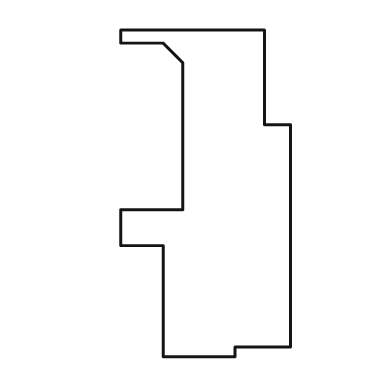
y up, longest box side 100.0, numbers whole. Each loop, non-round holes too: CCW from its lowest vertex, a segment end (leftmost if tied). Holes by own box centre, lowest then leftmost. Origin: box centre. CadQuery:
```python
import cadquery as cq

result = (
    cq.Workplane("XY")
    .moveTo(-13.0, -50.0)
    .lineTo(9.0, -50.0)
    .lineTo(9.0, -47.0)
    .lineTo(26.0, -47.0)
    .lineTo(26.0, 21.0)
    .lineTo(18.0, 21.0)
    .lineTo(18.0, 50.0)
    .lineTo(-26.0, 50.0)
    .lineTo(-26.0, 46.0)
    .lineTo(-13.0, 46.0)
    .lineTo(-7.0, 40.0)
    .lineTo(-7.0, -5.0)
    .lineTo(-26.0, -5.0)
    .lineTo(-26.0, -16.0)
    .lineTo(-13.0, -16.0)
    .close()
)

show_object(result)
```